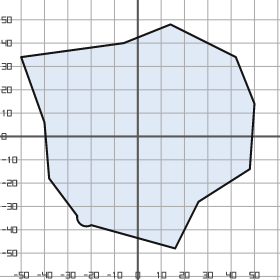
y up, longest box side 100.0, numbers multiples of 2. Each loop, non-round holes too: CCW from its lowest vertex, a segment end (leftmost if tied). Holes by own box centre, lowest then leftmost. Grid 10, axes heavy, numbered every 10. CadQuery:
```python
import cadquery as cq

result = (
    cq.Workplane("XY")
    .moveTo(16.0, -48.0)
    .lineTo(26.0, -28.0)
    .lineTo(48.0, -14.0)
    .lineTo(50.0, 14.0)
    .lineTo(42.0, 34.0)
    .lineTo(14.0, 48.0)
    .lineTo(-6.0, 40.0)
    .lineTo(-50.0, 34.0)
    .lineTo(-40.0, 6.0)
    .lineTo(-38.0, -18.0)
    .lineTo(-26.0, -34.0)
    .threePointArc((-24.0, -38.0), (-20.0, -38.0))
    .close()
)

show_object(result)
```